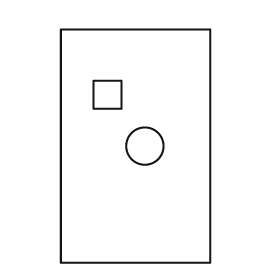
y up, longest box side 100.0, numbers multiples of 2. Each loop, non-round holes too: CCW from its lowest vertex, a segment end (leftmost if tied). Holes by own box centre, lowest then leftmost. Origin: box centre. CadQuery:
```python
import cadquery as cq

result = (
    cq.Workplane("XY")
    .moveTo(-32.0, -50.0)
    .lineTo(32.0, -50.0)
    .lineTo(32.0, 50.0)
    .lineTo(-32.0, 50.0)
    .close()
    .moveTo(4.0, 0.0)
    .circle(8.0)
    .moveTo(-18.0, 16.0)
    .lineTo(-6.0, 16.0)
    .lineTo(-6.0, 28.0)
    .lineTo(-18.0, 28.0)
    .close()
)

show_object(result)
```